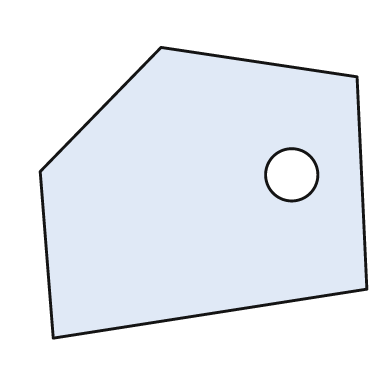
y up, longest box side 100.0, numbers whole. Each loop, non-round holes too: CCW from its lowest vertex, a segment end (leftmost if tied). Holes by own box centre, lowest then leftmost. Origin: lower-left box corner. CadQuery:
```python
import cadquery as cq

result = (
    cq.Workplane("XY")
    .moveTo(4.0, 0.0)
    .lineTo(100.0, 15.0)
    .lineTo(97.0, 80.0)
    .lineTo(37.0, 89.0)
    .lineTo(0.0, 51.0)
    .close()
    .moveTo(77.0, 50.0)
    .circle(8.0)
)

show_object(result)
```